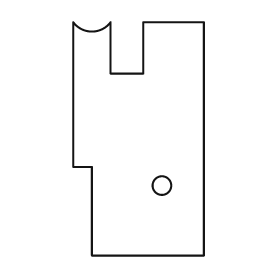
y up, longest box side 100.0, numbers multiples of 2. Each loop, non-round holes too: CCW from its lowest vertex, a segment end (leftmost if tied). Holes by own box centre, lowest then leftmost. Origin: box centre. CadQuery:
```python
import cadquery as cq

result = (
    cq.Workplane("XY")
    .moveTo(-20.0, -50.0)
    .lineTo(28.0, -50.0)
    .lineTo(28.0, 50.0)
    .lineTo(2.0, 50.0)
    .lineTo(2.0, 28.0)
    .lineTo(-12.0, 28.0)
    .lineTo(-12.0, 50.0)
    .threePointArc((-20.0, 46.0), (-28.0, 50.0))
    .lineTo(-28.0, -12.0)
    .lineTo(-20.0, -12.0)
    .close()
    .moveTo(10.0, -20.0)
    .circle(4.0)
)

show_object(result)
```